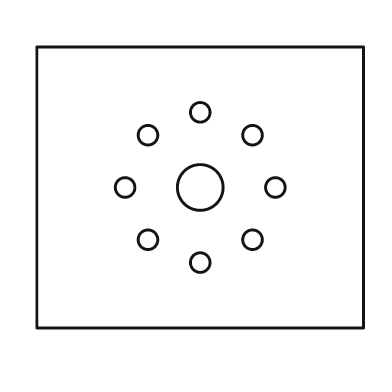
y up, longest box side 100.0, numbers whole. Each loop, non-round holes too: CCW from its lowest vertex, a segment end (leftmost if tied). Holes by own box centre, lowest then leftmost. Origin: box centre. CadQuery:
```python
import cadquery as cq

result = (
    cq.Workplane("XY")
    .moveTo(-50.0, -43.0)
    .lineTo(50.0, -43.0)
    .lineTo(50.0, 43.0)
    .lineTo(-50.0, 43.0)
    .close()
    .moveTo(0.0, -23.0)
    .circle(3.0)
    .moveTo(-16.0, -16.0)
    .circle(3.0)
    .moveTo(16.0, -16.0)
    .circle(3.0)
    .moveTo(-23.0, 0.0)
    .circle(3.0)
    .moveTo(0.0, 0.0)
    .circle(7.0)
    .moveTo(23.0, 0.0)
    .circle(3.0)
    .moveTo(-16.0, 16.0)
    .circle(3.0)
    .moveTo(16.0, 16.0)
    .circle(3.0)
    .moveTo(0.0, 23.0)
    .circle(3.0)
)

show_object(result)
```